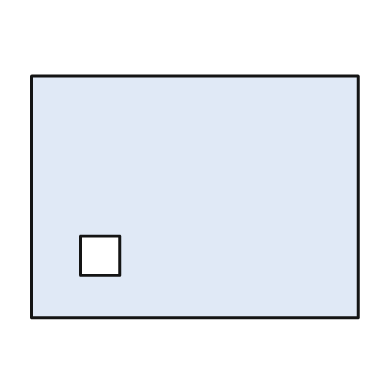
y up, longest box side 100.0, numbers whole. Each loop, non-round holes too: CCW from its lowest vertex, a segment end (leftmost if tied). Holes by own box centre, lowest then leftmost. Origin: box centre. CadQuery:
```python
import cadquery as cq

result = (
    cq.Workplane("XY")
    .moveTo(-50.0, -37.0)
    .lineTo(50.0, -37.0)
    .lineTo(50.0, 37.0)
    .lineTo(-50.0, 37.0)
    .close()
    .moveTo(-35.0, -24.0)
    .lineTo(-23.0, -24.0)
    .lineTo(-23.0, -12.0)
    .lineTo(-35.0, -12.0)
    .close()
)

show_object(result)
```